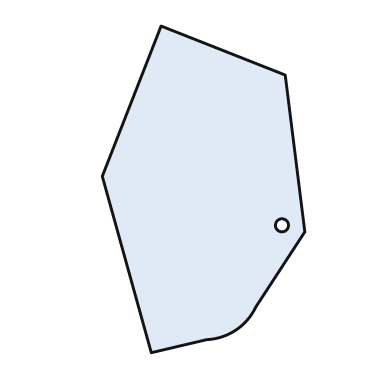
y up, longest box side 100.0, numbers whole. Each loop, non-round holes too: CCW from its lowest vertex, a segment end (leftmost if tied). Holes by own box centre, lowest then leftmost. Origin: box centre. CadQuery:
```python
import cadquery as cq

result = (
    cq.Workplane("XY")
    .moveTo(-16.0, -50.0)
    .lineTo(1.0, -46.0)
    .threePointArc((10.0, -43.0), (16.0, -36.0))
    .lineTo(31.0, -13.0)
    .lineTo(25.0, 35.0)
    .lineTo(-13.0, 50.0)
    .lineTo(-31.0, 4.0)
    .close()
    .moveTo(24.0, -11.0)
    .circle(2.0)
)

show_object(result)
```